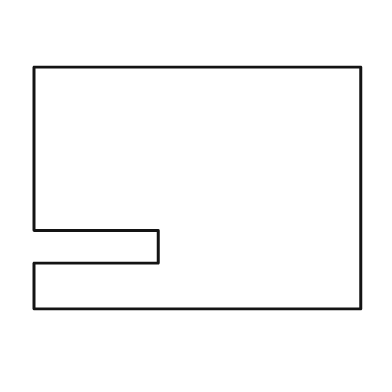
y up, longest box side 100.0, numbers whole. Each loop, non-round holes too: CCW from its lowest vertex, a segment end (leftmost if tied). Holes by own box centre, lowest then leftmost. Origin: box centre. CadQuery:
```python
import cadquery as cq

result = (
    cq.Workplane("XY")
    .moveTo(-50.0, -37.0)
    .lineTo(50.0, -37.0)
    .lineTo(50.0, 37.0)
    .lineTo(-50.0, 37.0)
    .lineTo(-50.0, -13.0)
    .lineTo(-12.0, -13.0)
    .lineTo(-12.0, -23.0)
    .lineTo(-50.0, -23.0)
    .close()
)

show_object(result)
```